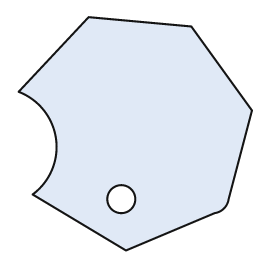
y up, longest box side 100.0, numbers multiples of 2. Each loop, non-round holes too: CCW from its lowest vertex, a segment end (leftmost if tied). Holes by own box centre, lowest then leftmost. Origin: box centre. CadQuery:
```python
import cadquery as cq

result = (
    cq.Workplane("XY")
    .moveTo(-4.0, -50.0)
    .lineTo(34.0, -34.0)
    .threePointArc((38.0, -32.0), (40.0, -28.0))
    .lineTo(50.0, 10.0)
    .lineTo(24.0, 46.0)
    .lineTo(-20.0, 50.0)
    .lineTo(-50.0, 18.0)
    .threePointArc((-34.0, -2.0), (-44.0, -26.0))
    .close()
    .moveTo(-6.0, -28.0)
    .circle(6.0)
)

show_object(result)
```